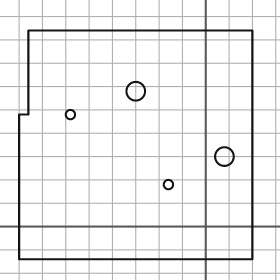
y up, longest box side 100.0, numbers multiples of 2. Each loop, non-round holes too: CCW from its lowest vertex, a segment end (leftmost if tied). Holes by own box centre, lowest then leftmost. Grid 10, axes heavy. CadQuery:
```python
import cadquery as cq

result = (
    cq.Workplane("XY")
    .moveTo(-80.0, -14.0)
    .lineTo(20.0, -14.0)
    .lineTo(20.0, 84.0)
    .lineTo(-76.0, 84.0)
    .lineTo(-76.0, 48.0)
    .lineTo(-80.0, 48.0)
    .close()
    .moveTo(-16.0, 18.0)
    .circle(2.0)
    .moveTo(8.0, 30.0)
    .circle(4.0)
    .moveTo(-58.0, 48.0)
    .circle(2.0)
    .moveTo(-30.0, 58.0)
    .circle(4.0)
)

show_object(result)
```